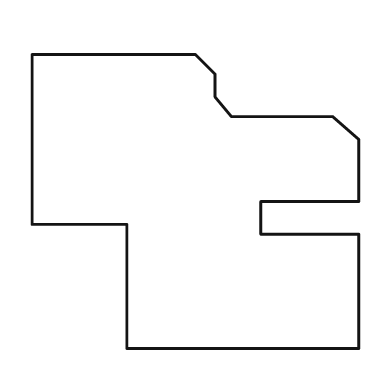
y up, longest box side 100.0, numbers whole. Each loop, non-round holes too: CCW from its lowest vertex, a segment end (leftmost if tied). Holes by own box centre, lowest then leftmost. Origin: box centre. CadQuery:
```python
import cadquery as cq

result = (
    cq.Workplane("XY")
    .moveTo(-21.0, -45.0)
    .lineTo(50.0, -45.0)
    .lineTo(50.0, -10.0)
    .lineTo(20.0, -10.0)
    .lineTo(20.0, 0.0)
    .lineTo(50.0, 0.0)
    .lineTo(50.0, 19.0)
    .lineTo(42.0, 26.0)
    .lineTo(11.0, 26.0)
    .lineTo(6.0, 32.0)
    .lineTo(6.0, 39.0)
    .lineTo(0.0, 45.0)
    .lineTo(-50.0, 45.0)
    .lineTo(-50.0, -7.0)
    .lineTo(-21.0, -7.0)
    .close()
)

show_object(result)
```